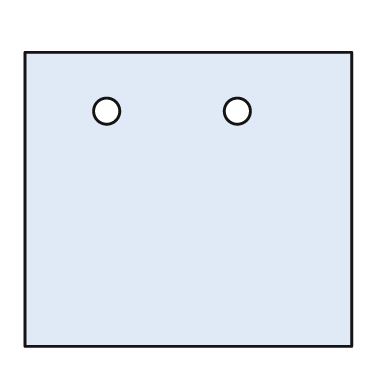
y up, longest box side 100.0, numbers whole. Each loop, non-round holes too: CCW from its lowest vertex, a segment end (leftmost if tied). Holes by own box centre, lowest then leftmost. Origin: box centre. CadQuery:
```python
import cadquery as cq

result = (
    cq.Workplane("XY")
    .moveTo(-50.0, -45.0)
    .lineTo(50.0, -45.0)
    .lineTo(50.0, 45.0)
    .lineTo(-50.0, 45.0)
    .close()
    .moveTo(-25.0, 27.0)
    .circle(4.0)
    .moveTo(15.0, 27.0)
    .circle(4.0)
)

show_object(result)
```